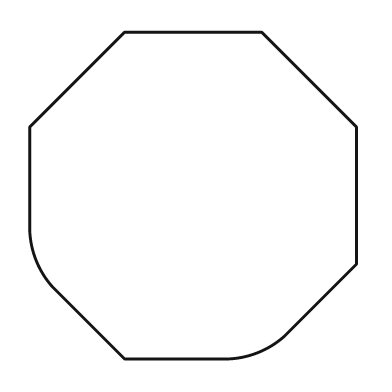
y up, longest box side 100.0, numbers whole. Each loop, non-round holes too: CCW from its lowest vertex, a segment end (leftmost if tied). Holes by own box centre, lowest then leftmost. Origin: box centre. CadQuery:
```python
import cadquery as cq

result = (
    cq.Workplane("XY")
    .moveTo(-21.0, -50.0)
    .lineTo(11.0, -50.0)
    .threePointArc((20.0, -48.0), (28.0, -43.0))
    .lineTo(50.0, -21.0)
    .lineTo(50.0, 21.0)
    .lineTo(21.0, 50.0)
    .lineTo(-21.0, 50.0)
    .lineTo(-50.0, 21.0)
    .lineTo(-50.0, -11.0)
    .threePointArc((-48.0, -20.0), (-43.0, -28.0))
    .close()
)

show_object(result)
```